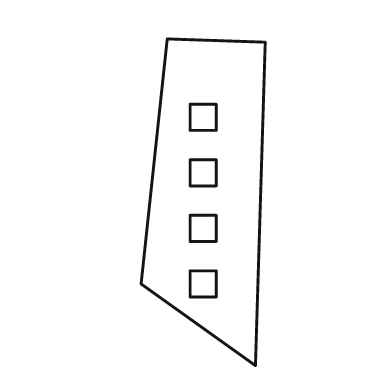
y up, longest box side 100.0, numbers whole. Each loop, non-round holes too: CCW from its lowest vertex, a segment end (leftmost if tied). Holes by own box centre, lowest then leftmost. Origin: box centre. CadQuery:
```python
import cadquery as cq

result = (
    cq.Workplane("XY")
    .moveTo(16.0, -50.0)
    .lineTo(19.0, 49.0)
    .lineTo(-11.0, 50.0)
    .lineTo(-19.0, -25.0)
    .close()
    .moveTo(-4.0, -29.0)
    .lineTo(4.0, -29.0)
    .lineTo(4.0, -21.0)
    .lineTo(-4.0, -21.0)
    .close()
    .moveTo(-4.0, -12.0)
    .lineTo(4.0, -12.0)
    .lineTo(4.0, -4.0)
    .lineTo(-4.0, -4.0)
    .close()
    .moveTo(-4.0, 5.0)
    .lineTo(4.0, 5.0)
    .lineTo(4.0, 13.0)
    .lineTo(-4.0, 13.0)
    .close()
    .moveTo(-4.0, 22.0)
    .lineTo(4.0, 22.0)
    .lineTo(4.0, 30.0)
    .lineTo(-4.0, 30.0)
    .close()
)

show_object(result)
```